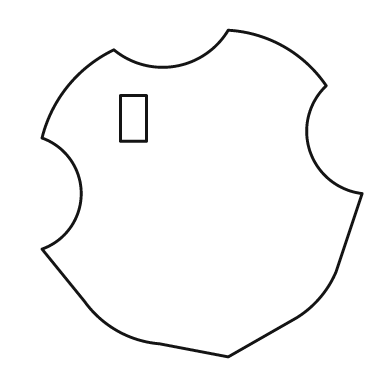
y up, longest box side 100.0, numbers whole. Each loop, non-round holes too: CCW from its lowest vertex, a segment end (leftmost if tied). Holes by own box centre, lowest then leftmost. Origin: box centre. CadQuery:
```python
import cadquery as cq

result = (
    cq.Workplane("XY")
    .moveTo(8.0, -50.0)
    .lineTo(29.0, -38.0)
    .threePointArc((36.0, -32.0), (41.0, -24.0))
    .lineTo(49.0, 0.0)
    .threePointArc((33.0, 13.0), (38.0, 33.0))
    .threePointArc((25.0, 45.0), (8.0, 50.0))
    .threePointArc((-8.0, 39.0), (-27.0, 44.0))
    .threePointArc((-41.0, 33.0), (-49.0, 17.0))
    .threePointArc((-37.0, 0.0), (-49.0, -17.0))
    .lineTo(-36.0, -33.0)
    .threePointArc((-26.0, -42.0), (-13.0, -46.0))
    .close()
    .moveTo(-25.0, 16.0)
    .lineTo(-17.0, 16.0)
    .lineTo(-17.0, 30.0)
    .lineTo(-25.0, 30.0)
    .close()
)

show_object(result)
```